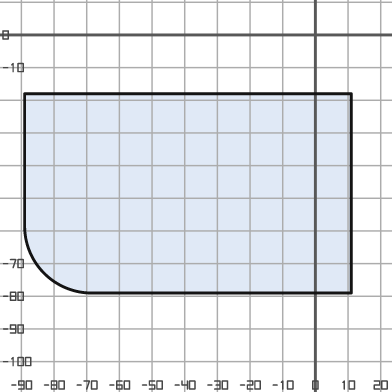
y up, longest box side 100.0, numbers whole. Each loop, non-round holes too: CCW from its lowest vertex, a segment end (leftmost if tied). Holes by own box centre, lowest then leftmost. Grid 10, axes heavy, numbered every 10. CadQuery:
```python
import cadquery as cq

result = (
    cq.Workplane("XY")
    .moveTo(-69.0, -79.0)
    .lineTo(11.0, -79.0)
    .lineTo(11.0, -18.0)
    .lineTo(-89.0, -18.0)
    .lineTo(-89.0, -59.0)
    .threePointArc((-83.0, -73.0), (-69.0, -79.0))
    .close()
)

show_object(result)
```